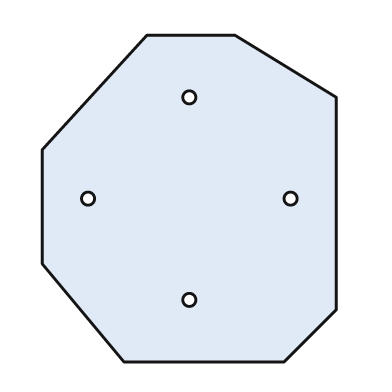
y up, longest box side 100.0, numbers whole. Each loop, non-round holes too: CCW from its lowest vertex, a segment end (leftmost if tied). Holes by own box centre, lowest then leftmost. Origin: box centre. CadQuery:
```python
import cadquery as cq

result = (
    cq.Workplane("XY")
    .moveTo(-20.0, -50.0)
    .lineTo(29.0, -50.0)
    .lineTo(45.0, -34.0)
    .lineTo(45.0, 31.0)
    .lineTo(14.0, 50.0)
    .lineTo(-13.0, 50.0)
    .lineTo(-45.0, 15.0)
    .lineTo(-45.0, -20.0)
    .close()
    .moveTo(0.0, -31.0)
    .circle(2.0)
    .moveTo(-31.0, 0.0)
    .circle(2.0)
    .moveTo(31.0, 0.0)
    .circle(2.0)
    .moveTo(0.0, 31.0)
    .circle(2.0)
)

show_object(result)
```